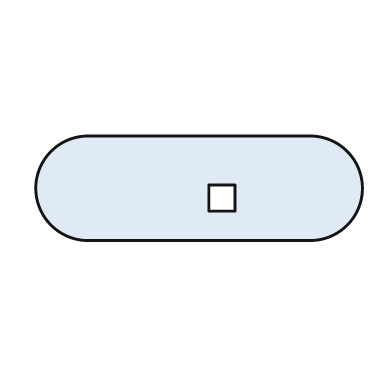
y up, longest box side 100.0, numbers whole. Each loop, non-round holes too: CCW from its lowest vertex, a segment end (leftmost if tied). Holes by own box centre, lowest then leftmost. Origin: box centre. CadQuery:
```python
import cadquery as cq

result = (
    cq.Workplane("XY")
    .moveTo(-34.0, -16.0)
    .lineTo(34.0, -16.0)
    .threePointArc((50.0, 0.0), (34.0, 16.0))
    .lineTo(-34.0, 16.0)
    .threePointArc((-50.0, 0.0), (-34.0, -16.0))
    .close()
    .moveTo(3.0, -7.0)
    .lineTo(11.0, -7.0)
    .lineTo(11.0, 1.0)
    .lineTo(3.0, 1.0)
    .close()
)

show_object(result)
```